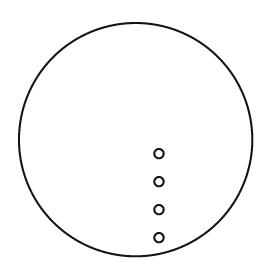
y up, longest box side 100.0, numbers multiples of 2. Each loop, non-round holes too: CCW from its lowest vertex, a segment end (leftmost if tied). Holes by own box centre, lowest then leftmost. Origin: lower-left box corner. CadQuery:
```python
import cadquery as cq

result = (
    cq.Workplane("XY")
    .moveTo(50.0, 50.0)
    .circle(50.0)
    .moveTo(60.0, 8.0)
    .circle(2.0)
    .moveTo(60.0, 20.0)
    .circle(2.0)
    .moveTo(60.0, 32.0)
    .circle(2.0)
    .moveTo(60.0, 44.0)
    .circle(2.0)
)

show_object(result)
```